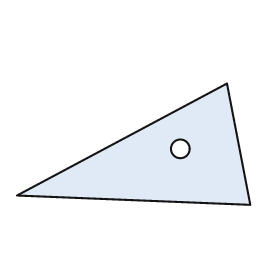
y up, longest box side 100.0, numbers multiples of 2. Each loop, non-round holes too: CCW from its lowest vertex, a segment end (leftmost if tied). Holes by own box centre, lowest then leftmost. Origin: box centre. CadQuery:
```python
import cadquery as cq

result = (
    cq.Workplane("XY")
    .moveTo(50.0, -26.0)
    .lineTo(40.0, 26.0)
    .lineTo(-50.0, -22.0)
    .close()
    .moveTo(20.0, -2.0)
    .circle(4.0)
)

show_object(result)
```